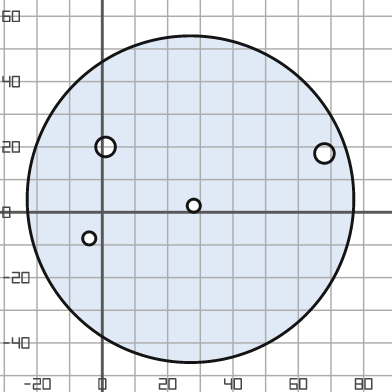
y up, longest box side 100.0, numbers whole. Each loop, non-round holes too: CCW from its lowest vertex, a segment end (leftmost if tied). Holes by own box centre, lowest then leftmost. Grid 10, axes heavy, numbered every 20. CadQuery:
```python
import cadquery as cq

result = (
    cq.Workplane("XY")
    .moveTo(27.0, 4.0)
    .circle(50.0)
    .moveTo(-4.0, -8.0)
    .circle(2.0)
    .moveTo(28.0, 2.0)
    .circle(2.0)
    .moveTo(68.0, 18.0)
    .circle(3.0)
    .moveTo(1.0, 20.0)
    .circle(3.0)
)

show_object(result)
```